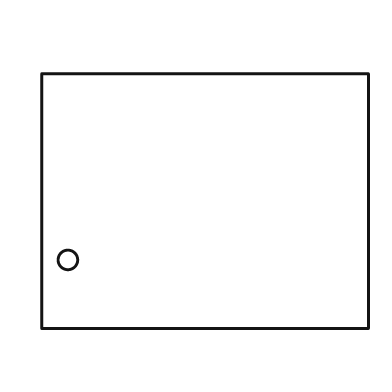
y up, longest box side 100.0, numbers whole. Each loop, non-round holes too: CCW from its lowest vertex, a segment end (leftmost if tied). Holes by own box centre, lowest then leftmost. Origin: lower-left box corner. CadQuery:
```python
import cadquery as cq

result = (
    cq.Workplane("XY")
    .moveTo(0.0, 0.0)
    .lineTo(100.0, 0.0)
    .lineTo(100.0, 78.0)
    .lineTo(0.0, 78.0)
    .close()
    .moveTo(8.0, 21.0)
    .circle(3.0)
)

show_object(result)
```